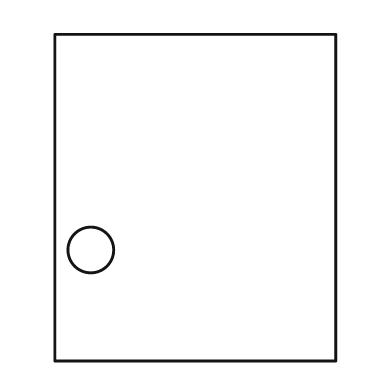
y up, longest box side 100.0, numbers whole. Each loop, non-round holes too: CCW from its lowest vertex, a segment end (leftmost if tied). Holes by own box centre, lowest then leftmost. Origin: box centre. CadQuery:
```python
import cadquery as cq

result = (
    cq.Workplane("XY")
    .moveTo(-43.0, -50.0)
    .lineTo(43.0, -50.0)
    .lineTo(43.0, 50.0)
    .lineTo(-43.0, 50.0)
    .close()
    .moveTo(-32.0, -16.0)
    .circle(7.0)
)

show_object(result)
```